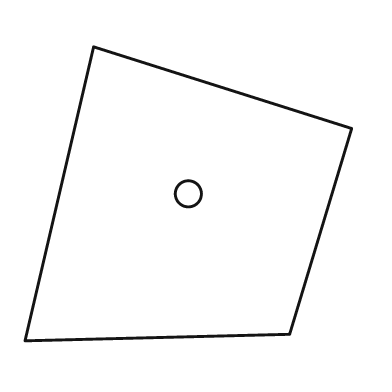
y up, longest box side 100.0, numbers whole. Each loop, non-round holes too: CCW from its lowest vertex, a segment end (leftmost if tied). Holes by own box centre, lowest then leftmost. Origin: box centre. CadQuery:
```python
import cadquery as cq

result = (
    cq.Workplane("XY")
    .moveTo(-50.0, -45.0)
    .lineTo(31.0, -43.0)
    .lineTo(50.0, 20.0)
    .lineTo(-29.0, 45.0)
    .close()
    .moveTo(0.0, 0.0)
    .circle(4.0)
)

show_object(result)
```